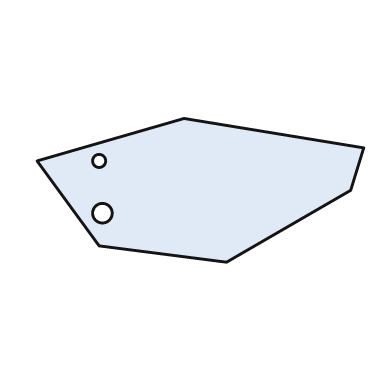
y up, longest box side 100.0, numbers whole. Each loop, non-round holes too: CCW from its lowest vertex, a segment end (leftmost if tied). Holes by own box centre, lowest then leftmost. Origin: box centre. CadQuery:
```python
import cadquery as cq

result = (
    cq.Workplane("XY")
    .moveTo(8.0, -22.0)
    .lineTo(46.0, 0.0)
    .lineTo(50.0, 13.0)
    .lineTo(-5.0, 22.0)
    .lineTo(-50.0, 9.0)
    .lineTo(-31.0, -17.0)
    .close()
    .moveTo(-30.0, -7.0)
    .circle(3.0)
    .moveTo(-31.0, 9.0)
    .circle(2.0)
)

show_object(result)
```